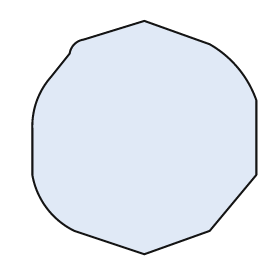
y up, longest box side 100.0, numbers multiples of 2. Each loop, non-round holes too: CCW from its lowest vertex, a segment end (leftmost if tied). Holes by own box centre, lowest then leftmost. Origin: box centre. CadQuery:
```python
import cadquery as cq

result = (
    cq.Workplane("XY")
    .moveTo(0.0, -50.0)
    .lineTo(28.0, -40.0)
    .lineTo(48.0, -16.0)
    .lineTo(48.0, 16.0)
    .threePointArc((40.0, 30.0), (28.0, 40.0))
    .lineTo(0.0, 50.0)
    .lineTo(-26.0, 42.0)
    .threePointArc((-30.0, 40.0), (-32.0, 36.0))
    .lineTo(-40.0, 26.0)
    .threePointArc((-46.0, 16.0), (-48.0, 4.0))
    .lineTo(-48.0, -16.0)
    .threePointArc((-42.0, -30.0), (-30.0, -40.0))
    .close()
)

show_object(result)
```